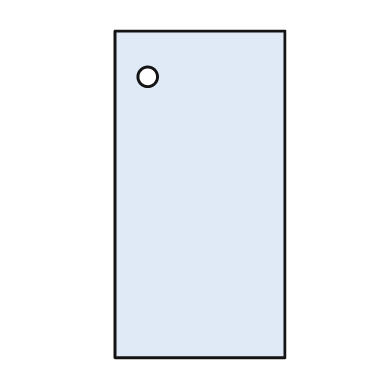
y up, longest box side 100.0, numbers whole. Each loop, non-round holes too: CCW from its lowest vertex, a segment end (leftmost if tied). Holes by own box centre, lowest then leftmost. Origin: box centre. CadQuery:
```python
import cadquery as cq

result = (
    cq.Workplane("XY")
    .moveTo(-26.0, -50.0)
    .lineTo(26.0, -50.0)
    .lineTo(26.0, 50.0)
    .lineTo(-26.0, 50.0)
    .close()
    .moveTo(-16.0, 36.0)
    .circle(3.0)
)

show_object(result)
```